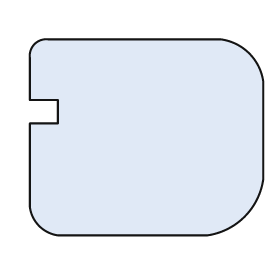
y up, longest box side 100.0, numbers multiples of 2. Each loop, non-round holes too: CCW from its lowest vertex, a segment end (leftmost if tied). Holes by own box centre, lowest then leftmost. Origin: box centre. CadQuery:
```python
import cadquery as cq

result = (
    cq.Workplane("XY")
    .moveTo(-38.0, -42.0)
    .lineTo(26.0, -42.0)
    .threePointArc((42.0, -34.0), (50.0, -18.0))
    .lineTo(50.0, 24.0)
    .threePointArc((44.0, 36.0), (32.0, 42.0))
    .lineTo(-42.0, 42.0)
    .threePointArc((-48.0, 40.0), (-50.0, 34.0))
    .lineTo(-50.0, 16.0)
    .lineTo(-38.0, 16.0)
    .lineTo(-38.0, 6.0)
    .lineTo(-50.0, 6.0)
    .lineTo(-50.0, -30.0)
    .threePointArc((-46.0, -38.0), (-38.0, -42.0))
    .close()
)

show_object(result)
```